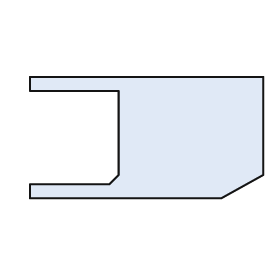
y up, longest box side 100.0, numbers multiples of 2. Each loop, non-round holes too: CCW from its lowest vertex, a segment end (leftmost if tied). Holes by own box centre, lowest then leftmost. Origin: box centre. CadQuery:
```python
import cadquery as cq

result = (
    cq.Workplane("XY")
    .moveTo(-50.0, -26.0)
    .lineTo(32.0, -26.0)
    .lineTo(50.0, -16.0)
    .lineTo(50.0, 26.0)
    .lineTo(-50.0, 26.0)
    .lineTo(-50.0, 20.0)
    .lineTo(-12.0, 20.0)
    .lineTo(-12.0, -16.0)
    .lineTo(-16.0, -20.0)
    .lineTo(-50.0, -20.0)
    .close()
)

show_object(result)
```